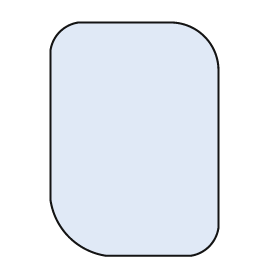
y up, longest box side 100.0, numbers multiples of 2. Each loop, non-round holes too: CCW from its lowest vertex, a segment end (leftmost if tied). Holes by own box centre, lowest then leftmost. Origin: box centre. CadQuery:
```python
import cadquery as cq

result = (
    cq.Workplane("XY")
    .moveTo(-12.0, -50.0)
    .lineTo(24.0, -50.0)
    .threePointArc((32.0, -46.0), (36.0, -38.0))
    .lineTo(36.0, 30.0)
    .threePointArc((30.0, 44.0), (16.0, 50.0))
    .lineTo(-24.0, 50.0)
    .threePointArc((-32.0, 46.0), (-36.0, 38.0))
    .lineTo(-36.0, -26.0)
    .threePointArc((-28.0, -42.0), (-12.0, -50.0))
    .close()
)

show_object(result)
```